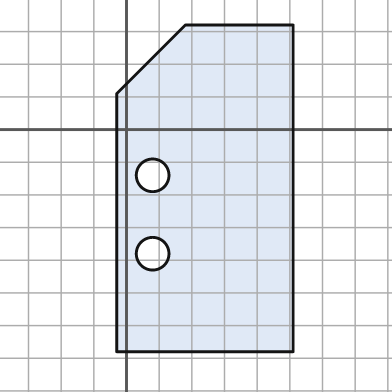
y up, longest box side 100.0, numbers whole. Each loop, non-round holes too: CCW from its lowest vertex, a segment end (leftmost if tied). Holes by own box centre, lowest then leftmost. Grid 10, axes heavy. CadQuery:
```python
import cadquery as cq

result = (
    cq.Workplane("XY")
    .moveTo(-3.0, -68.0)
    .lineTo(51.0, -68.0)
    .lineTo(51.0, 32.0)
    .lineTo(18.0, 32.0)
    .lineTo(-3.0, 11.0)
    .close()
    .moveTo(8.0, -38.0)
    .circle(5.0)
    .moveTo(8.0, -14.0)
    .circle(5.0)
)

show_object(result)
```